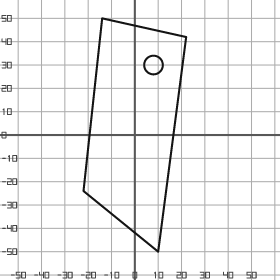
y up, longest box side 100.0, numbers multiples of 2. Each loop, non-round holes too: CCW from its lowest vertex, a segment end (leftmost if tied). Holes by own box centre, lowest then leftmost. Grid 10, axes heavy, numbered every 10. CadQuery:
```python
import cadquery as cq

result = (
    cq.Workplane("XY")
    .moveTo(10.0, -50.0)
    .lineTo(22.0, 42.0)
    .lineTo(-14.0, 50.0)
    .lineTo(-22.0, -24.0)
    .close()
    .moveTo(8.0, 30.0)
    .circle(4.0)
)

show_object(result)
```